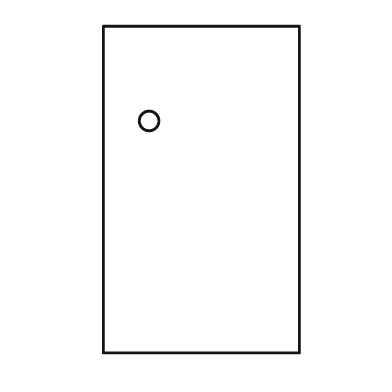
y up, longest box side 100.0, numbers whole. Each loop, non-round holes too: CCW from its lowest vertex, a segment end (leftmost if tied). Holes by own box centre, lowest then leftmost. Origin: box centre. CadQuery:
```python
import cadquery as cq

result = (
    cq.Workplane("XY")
    .moveTo(-30.0, -50.0)
    .lineTo(30.0, -50.0)
    .lineTo(30.0, 50.0)
    .lineTo(-30.0, 50.0)
    .close()
    .moveTo(-16.0, 21.0)
    .circle(3.0)
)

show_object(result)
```